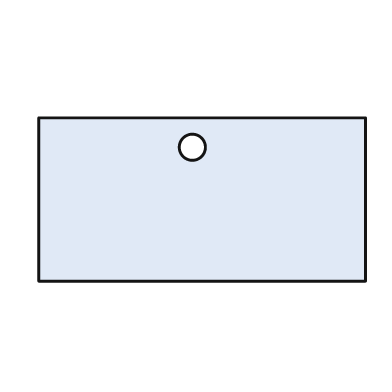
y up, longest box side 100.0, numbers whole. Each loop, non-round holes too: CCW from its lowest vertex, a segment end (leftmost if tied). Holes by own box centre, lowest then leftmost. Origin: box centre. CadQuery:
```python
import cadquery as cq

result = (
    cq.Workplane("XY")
    .moveTo(-50.0, -25.0)
    .lineTo(50.0, -25.0)
    .lineTo(50.0, 25.0)
    .lineTo(-50.0, 25.0)
    .close()
    .moveTo(-3.0, 16.0)
    .circle(4.0)
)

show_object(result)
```